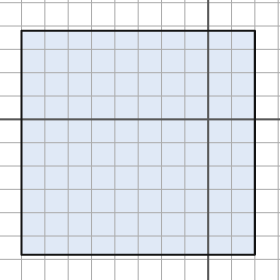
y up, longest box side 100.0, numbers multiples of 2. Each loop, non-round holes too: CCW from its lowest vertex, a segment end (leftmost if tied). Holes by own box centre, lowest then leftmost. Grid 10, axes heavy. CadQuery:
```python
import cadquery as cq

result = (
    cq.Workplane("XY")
    .moveTo(-80.0, -58.0)
    .lineTo(20.0, -58.0)
    .lineTo(20.0, 38.0)
    .lineTo(-80.0, 38.0)
    .close()
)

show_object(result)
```